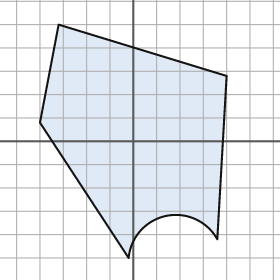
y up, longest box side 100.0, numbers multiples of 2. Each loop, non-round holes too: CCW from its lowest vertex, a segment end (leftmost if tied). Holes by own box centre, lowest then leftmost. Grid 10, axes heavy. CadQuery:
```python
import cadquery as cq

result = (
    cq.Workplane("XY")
    .moveTo(-2.0, -50.0)
    .threePointArc((14.0, -32.0), (36.0, -42.0))
    .lineTo(40.0, 28.0)
    .lineTo(-32.0, 50.0)
    .lineTo(-40.0, 8.0)
    .close()
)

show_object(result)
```